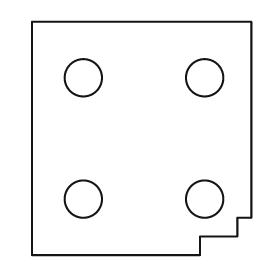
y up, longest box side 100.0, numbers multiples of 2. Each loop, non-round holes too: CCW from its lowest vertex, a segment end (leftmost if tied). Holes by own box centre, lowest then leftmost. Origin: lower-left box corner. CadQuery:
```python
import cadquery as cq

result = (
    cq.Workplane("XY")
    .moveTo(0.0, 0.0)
    .lineTo(72.0, 0.0)
    .lineTo(72.0, 8.0)
    .lineTo(88.0, 8.0)
    .lineTo(88.0, 16.0)
    .lineTo(94.0, 16.0)
    .lineTo(94.0, 100.0)
    .lineTo(0.0, 100.0)
    .close()
    .moveTo(22.0, 24.0)
    .circle(8.0)
    .moveTo(74.0, 24.0)
    .circle(8.0)
    .moveTo(22.0, 76.0)
    .circle(8.0)
    .moveTo(74.0, 76.0)
    .circle(8.0)
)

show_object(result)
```